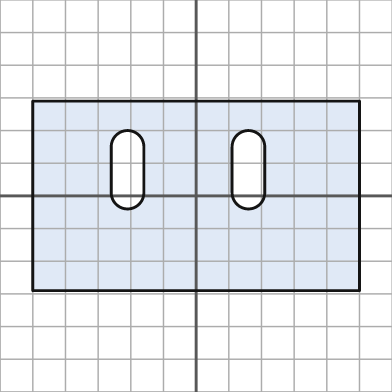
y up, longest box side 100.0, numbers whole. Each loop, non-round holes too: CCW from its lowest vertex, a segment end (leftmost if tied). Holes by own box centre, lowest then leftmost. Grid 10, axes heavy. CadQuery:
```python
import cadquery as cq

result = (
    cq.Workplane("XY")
    .moveTo(-50.0, -29.0)
    .lineTo(50.0, -29.0)
    .lineTo(50.0, 29.0)
    .lineTo(-50.0, 29.0)
    .close()
    .moveTo(-26.0, 1.0)
    .threePointArc((-21.0, -4.0), (-16.0, 1.0))
    .lineTo(-16.0, 15.0)
    .threePointArc((-21.0, 20.0), (-26.0, 15.0))
    .close()
    .moveTo(11.0, 1.0)
    .threePointArc((16.0, -4.0), (21.0, 1.0))
    .lineTo(21.0, 15.0)
    .threePointArc((16.0, 20.0), (11.0, 15.0))
    .close()
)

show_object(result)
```